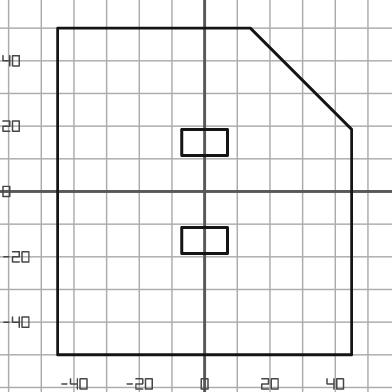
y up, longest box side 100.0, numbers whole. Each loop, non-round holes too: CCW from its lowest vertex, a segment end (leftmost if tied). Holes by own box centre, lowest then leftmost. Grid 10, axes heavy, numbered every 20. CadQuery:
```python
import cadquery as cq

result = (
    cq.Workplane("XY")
    .moveTo(-45.0, -50.0)
    .lineTo(45.0, -50.0)
    .lineTo(45.0, 19.0)
    .lineTo(14.0, 50.0)
    .lineTo(-45.0, 50.0)
    .close()
    .moveTo(-7.0, -19.0)
    .lineTo(7.0, -19.0)
    .lineTo(7.0, -11.0)
    .lineTo(-7.0, -11.0)
    .close()
    .moveTo(-7.0, 11.0)
    .lineTo(7.0, 11.0)
    .lineTo(7.0, 19.0)
    .lineTo(-7.0, 19.0)
    .close()
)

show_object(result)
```